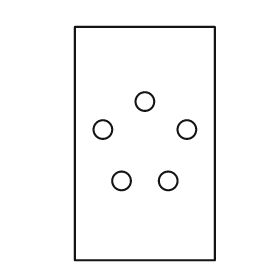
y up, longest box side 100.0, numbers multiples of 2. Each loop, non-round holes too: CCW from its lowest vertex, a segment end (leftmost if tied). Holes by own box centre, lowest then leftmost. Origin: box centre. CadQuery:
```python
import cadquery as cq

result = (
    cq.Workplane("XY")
    .moveTo(-30.0, -50.0)
    .lineTo(30.0, -50.0)
    .lineTo(30.0, 50.0)
    .lineTo(-30.0, 50.0)
    .close()
    .moveTo(-10.0, -16.0)
    .circle(4.0)
    .moveTo(10.0, -16.0)
    .circle(4.0)
    .moveTo(-18.0, 6.0)
    .circle(4.0)
    .moveTo(18.0, 6.0)
    .circle(4.0)
    .moveTo(0.0, 18.0)
    .circle(4.0)
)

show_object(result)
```